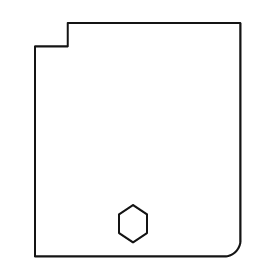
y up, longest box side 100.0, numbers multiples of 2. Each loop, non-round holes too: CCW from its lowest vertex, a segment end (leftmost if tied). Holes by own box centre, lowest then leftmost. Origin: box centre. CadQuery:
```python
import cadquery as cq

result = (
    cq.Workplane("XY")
    .moveTo(-44.0, -50.0)
    .lineTo(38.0, -50.0)
    .threePointArc((42.0, -48.0), (44.0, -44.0))
    .lineTo(44.0, 50.0)
    .lineTo(-30.0, 50.0)
    .lineTo(-30.0, 40.0)
    .lineTo(-44.0, 40.0)
    .close()
    .moveTo(-2.0, -44.0)
    .lineTo(4.0, -40.0)
    .lineTo(4.0, -32.0)
    .lineTo(-2.0, -28.0)
    .lineTo(-8.0, -32.0)
    .lineTo(-8.0, -40.0)
    .close()
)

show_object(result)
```